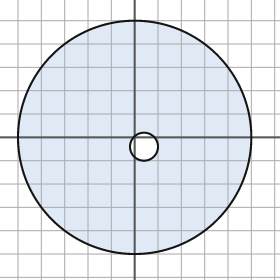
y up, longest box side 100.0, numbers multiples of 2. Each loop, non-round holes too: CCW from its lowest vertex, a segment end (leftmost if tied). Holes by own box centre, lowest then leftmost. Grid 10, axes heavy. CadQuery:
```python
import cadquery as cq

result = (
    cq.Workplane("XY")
    .moveTo(0.0, 0.0)
    .circle(50.0)
    .moveTo(4.0, -4.0)
    .circle(6.0)
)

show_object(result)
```